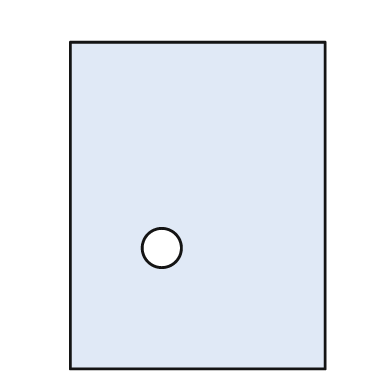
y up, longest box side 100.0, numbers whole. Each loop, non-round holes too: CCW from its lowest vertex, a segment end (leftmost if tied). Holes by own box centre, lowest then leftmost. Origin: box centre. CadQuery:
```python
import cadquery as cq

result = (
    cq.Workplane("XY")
    .moveTo(-39.0, -50.0)
    .lineTo(39.0, -50.0)
    .lineTo(39.0, 50.0)
    .lineTo(-39.0, 50.0)
    .close()
    .moveTo(-11.0, -13.0)
    .circle(6.0)
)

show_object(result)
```